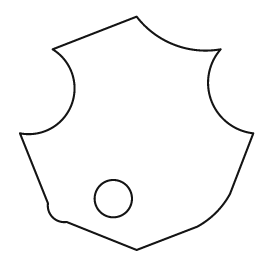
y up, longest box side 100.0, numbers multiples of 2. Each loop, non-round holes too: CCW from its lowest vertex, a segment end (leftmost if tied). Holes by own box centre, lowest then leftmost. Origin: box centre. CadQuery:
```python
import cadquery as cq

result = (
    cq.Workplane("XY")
    .moveTo(0.0, -50.0)
    .lineTo(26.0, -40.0)
    .threePointArc((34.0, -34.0), (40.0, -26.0))
    .lineTo(50.0, 0.0)
    .threePointArc((32.0, 14.0), (36.0, 36.0))
    .threePointArc((16.0, 38.0), (0.0, 50.0))
    .lineTo(-36.0, 36.0)
    .threePointArc((-28.0, 12.0), (-50.0, 0.0))
    .lineTo(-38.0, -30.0)
    .threePointArc((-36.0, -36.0), (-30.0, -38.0))
    .close()
    .moveTo(-10.0, -28.0)
    .circle(8.0)
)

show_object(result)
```